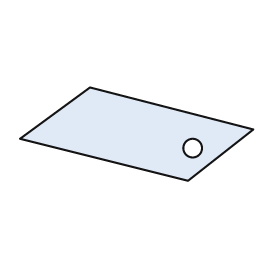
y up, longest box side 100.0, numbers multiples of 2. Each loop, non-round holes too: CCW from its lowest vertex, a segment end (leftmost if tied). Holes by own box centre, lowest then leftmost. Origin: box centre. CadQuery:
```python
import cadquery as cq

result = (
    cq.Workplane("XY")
    .moveTo(22.0, -20.0)
    .lineTo(50.0, 2.0)
    .lineTo(-20.0, 20.0)
    .lineTo(-50.0, -2.0)
    .close()
    .moveTo(24.0, -6.0)
    .circle(4.0)
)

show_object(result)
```